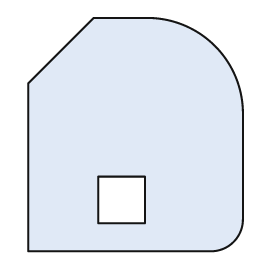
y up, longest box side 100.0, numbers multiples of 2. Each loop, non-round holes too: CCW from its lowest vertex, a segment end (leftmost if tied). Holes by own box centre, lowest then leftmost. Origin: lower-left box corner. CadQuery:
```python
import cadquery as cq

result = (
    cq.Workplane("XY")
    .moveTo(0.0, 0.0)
    .lineTo(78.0, 0.0)
    .threePointArc((88.0, 4.0), (92.0, 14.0))
    .lineTo(92.0, 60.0)
    .threePointArc((80.0, 88.0), (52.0, 100.0))
    .lineTo(28.0, 100.0)
    .lineTo(0.0, 72.0)
    .close()
    .moveTo(30.0, 12.0)
    .lineTo(50.0, 12.0)
    .lineTo(50.0, 32.0)
    .lineTo(30.0, 32.0)
    .close()
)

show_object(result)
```